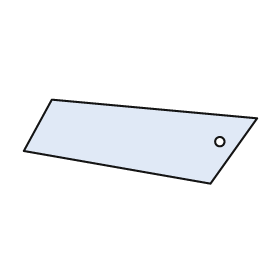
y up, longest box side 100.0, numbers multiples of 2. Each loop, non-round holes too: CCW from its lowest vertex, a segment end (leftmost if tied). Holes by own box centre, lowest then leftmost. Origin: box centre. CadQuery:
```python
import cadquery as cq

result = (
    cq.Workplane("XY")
    .moveTo(30.0, -18.0)
    .lineTo(50.0, 10.0)
    .lineTo(-38.0, 18.0)
    .lineTo(-50.0, -4.0)
    .close()
    .moveTo(34.0, 0.0)
    .circle(2.0)
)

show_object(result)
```